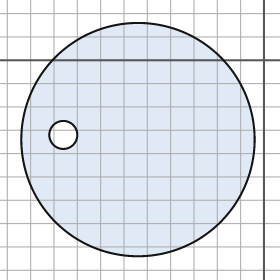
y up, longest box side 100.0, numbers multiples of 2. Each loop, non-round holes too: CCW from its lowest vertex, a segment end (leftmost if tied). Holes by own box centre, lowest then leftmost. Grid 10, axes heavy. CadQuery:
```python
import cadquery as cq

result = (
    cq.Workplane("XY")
    .moveTo(-54.0, -34.0)
    .circle(50.0)
    .moveTo(-86.0, -32.0)
    .circle(6.0)
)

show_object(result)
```